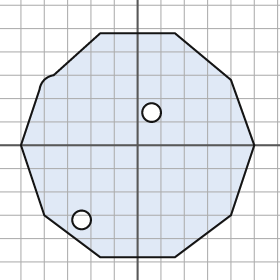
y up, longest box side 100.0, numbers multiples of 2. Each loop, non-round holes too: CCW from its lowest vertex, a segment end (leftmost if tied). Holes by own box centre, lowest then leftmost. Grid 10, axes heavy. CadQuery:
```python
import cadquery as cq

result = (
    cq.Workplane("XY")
    .moveTo(-16.0, -48.0)
    .lineTo(16.0, -48.0)
    .lineTo(40.0, -30.0)
    .lineTo(50.0, 0.0)
    .lineTo(40.0, 28.0)
    .lineTo(16.0, 48.0)
    .lineTo(-16.0, 48.0)
    .lineTo(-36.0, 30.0)
    .threePointArc((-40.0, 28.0), (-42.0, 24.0))
    .lineTo(-50.0, 0.0)
    .lineTo(-40.0, -30.0)
    .close()
    .moveTo(-24.0, -32.0)
    .circle(4.0)
    .moveTo(6.0, 14.0)
    .circle(4.0)
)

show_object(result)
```